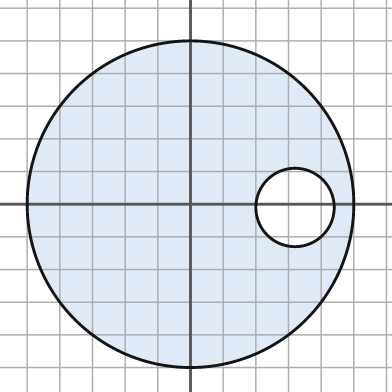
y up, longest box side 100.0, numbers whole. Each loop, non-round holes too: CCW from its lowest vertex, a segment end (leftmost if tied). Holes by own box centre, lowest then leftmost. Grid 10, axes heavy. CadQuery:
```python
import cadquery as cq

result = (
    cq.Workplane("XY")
    .moveTo(0.0, 0.0)
    .circle(50.0)
    .moveTo(32.0, -1.0)
    .circle(12.0)
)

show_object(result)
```